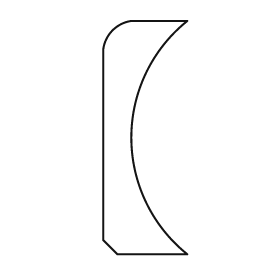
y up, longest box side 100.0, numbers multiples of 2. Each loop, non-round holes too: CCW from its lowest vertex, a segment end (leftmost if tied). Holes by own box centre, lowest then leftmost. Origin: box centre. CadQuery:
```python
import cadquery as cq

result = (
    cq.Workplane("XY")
    .moveTo(-12.0, -50.0)
    .lineTo(18.0, -50.0)
    .threePointArc((-6.0, 0.0), (18.0, 50.0))
    .lineTo(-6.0, 50.0)
    .threePointArc((-14.0, 46.0), (-18.0, 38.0))
    .lineTo(-18.0, -44.0)
    .close()
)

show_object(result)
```